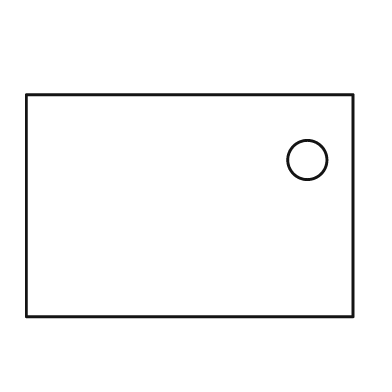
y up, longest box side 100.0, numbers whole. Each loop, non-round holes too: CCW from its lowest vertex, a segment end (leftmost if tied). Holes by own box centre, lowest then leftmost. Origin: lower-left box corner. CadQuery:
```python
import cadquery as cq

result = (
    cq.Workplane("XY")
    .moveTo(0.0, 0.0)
    .lineTo(100.0, 0.0)
    .lineTo(100.0, 68.0)
    .lineTo(0.0, 68.0)
    .close()
    .moveTo(86.0, 48.0)
    .circle(6.0)
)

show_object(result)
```